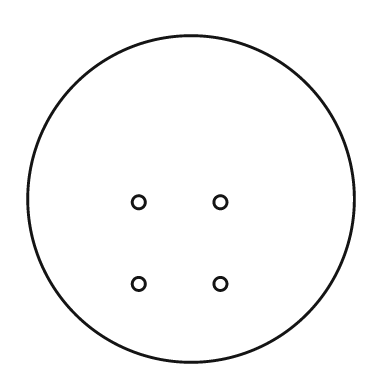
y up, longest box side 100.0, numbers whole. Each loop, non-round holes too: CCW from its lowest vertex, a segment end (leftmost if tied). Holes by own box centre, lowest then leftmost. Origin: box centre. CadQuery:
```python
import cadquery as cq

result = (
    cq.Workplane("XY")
    .moveTo(0.0, 0.0)
    .circle(50.0)
    .moveTo(-16.0, -26.0)
    .circle(2.0)
    .moveTo(9.0, -26.0)
    .circle(2.0)
    .moveTo(-16.0, -1.0)
    .circle(2.0)
    .moveTo(9.0, -1.0)
    .circle(2.0)
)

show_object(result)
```